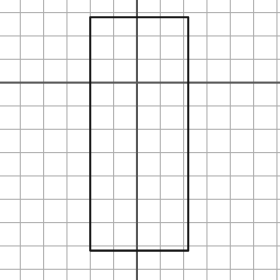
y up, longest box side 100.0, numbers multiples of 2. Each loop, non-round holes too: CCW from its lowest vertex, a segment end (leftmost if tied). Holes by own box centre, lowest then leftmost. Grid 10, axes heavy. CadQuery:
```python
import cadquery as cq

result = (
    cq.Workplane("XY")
    .moveTo(-20.0, -72.0)
    .lineTo(22.0, -72.0)
    .lineTo(22.0, 28.0)
    .lineTo(-20.0, 28.0)
    .close()
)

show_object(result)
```